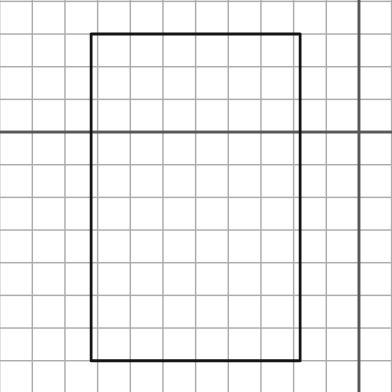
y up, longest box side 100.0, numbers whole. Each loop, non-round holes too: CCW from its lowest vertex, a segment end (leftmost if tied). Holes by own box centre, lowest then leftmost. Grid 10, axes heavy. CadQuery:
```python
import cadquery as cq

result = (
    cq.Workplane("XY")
    .moveTo(-82.0, -70.0)
    .lineTo(-18.0, -70.0)
    .lineTo(-18.0, 30.0)
    .lineTo(-82.0, 30.0)
    .close()
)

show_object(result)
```